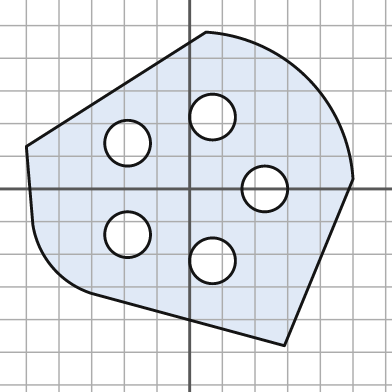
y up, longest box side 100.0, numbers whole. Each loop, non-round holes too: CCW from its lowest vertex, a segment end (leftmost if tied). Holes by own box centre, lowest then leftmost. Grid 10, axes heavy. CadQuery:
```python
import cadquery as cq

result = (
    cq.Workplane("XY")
    .moveTo(29.0, -48.0)
    .lineTo(50.0, 3.0)
    .threePointArc((36.0, 34.0), (5.0, 48.0))
    .lineTo(-50.0, 13.0)
    .lineTo(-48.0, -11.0)
    .threePointArc((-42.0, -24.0), (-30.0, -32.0))
    .close()
    .moveTo(7.0, -22.0)
    .circle(7.0)
    .moveTo(-19.0, -14.0)
    .circle(7.0)
    .moveTo(23.0, 0.0)
    .circle(7.0)
    .moveTo(-19.0, 14.0)
    .circle(7.0)
    .moveTo(7.0, 22.0)
    .circle(7.0)
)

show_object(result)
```